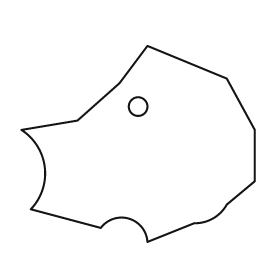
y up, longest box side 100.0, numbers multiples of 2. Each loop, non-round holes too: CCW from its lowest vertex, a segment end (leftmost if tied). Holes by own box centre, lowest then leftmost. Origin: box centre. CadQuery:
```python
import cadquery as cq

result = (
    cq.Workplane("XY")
    .moveTo(4.0, -42.0)
    .lineTo(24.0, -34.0)
    .threePointArc((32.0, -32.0), (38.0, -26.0))
    .lineTo(50.0, -16.0)
    .lineTo(50.0, 6.0)
    .lineTo(38.0, 28.0)
    .lineTo(4.0, 42.0)
    .lineTo(-8.0, 26.0)
    .lineTo(-26.0, 10.0)
    .lineTo(-50.0, 6.0)
    .threePointArc((-40.0, -10.0), (-46.0, -28.0))
    .lineTo(-16.0, -36.0)
    .threePointArc((-4.0, -32.0), (4.0, -42.0))
    .close()
    .moveTo(0.0, 16.0)
    .circle(4.0)
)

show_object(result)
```